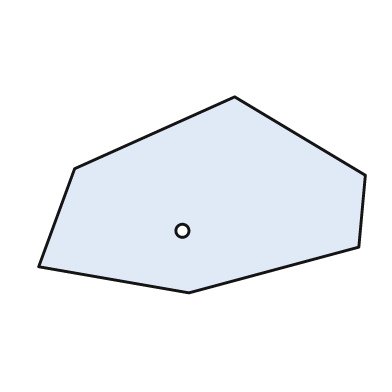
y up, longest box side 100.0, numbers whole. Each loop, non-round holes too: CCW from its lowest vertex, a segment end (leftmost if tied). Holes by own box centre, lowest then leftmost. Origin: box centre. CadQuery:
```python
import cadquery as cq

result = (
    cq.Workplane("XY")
    .moveTo(-4.0, -30.0)
    .lineTo(48.0, -16.0)
    .lineTo(50.0, 6.0)
    .lineTo(10.0, 30.0)
    .lineTo(-39.0, 8.0)
    .lineTo(-50.0, -22.0)
    .close()
    .moveTo(-6.0, -11.0)
    .circle(2.0)
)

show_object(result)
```